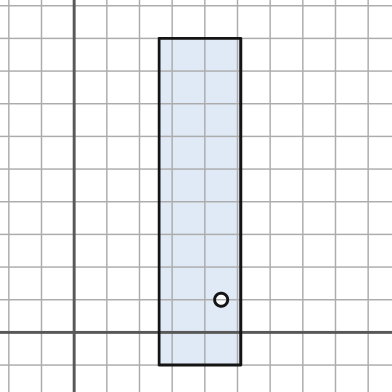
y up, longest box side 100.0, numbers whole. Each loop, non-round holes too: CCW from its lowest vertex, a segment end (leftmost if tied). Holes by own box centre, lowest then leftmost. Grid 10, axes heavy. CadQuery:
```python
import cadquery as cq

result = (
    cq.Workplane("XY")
    .moveTo(26.0, -10.0)
    .lineTo(51.0, -10.0)
    .lineTo(51.0, 90.0)
    .lineTo(26.0, 90.0)
    .close()
    .moveTo(45.0, 10.0)
    .circle(2.0)
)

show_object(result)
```